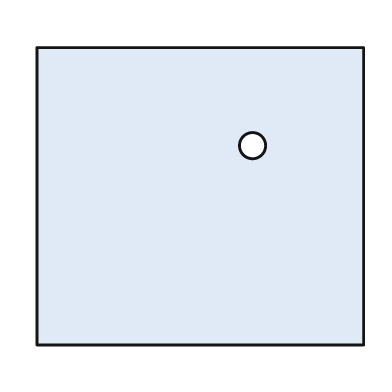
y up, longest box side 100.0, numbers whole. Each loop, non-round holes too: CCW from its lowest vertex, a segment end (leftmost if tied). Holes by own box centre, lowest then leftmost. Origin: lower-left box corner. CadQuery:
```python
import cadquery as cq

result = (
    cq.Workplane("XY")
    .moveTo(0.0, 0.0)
    .lineTo(100.0, 0.0)
    .lineTo(100.0, 91.0)
    .lineTo(0.0, 91.0)
    .close()
    .moveTo(66.0, 61.0)
    .circle(4.0)
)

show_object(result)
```